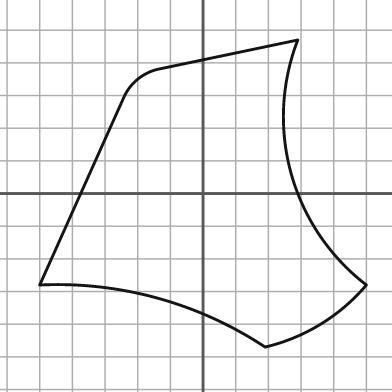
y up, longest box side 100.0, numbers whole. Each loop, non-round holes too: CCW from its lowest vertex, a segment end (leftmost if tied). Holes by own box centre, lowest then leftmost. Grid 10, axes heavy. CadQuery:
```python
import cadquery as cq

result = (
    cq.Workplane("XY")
    .moveTo(19.0, -47.0)
    .threePointArc((36.0, -40.0), (50.0, -28.0))
    .threePointArc((27.0, 6.0), (29.0, 47.0))
    .lineTo(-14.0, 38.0)
    .threePointArc((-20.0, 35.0), (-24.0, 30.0))
    .lineTo(-50.0, -28.0)
    .threePointArc((-14.0, -32.0), (19.0, -47.0))
    .close()
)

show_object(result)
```